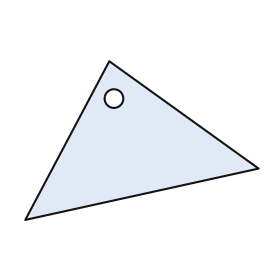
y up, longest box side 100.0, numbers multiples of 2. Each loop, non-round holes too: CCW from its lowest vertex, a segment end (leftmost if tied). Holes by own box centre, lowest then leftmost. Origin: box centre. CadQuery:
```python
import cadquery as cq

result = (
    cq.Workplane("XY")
    .moveTo(-50.0, -34.0)
    .lineTo(50.0, -12.0)
    .lineTo(-14.0, 34.0)
    .close()
    .moveTo(-12.0, 18.0)
    .circle(4.0)
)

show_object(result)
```